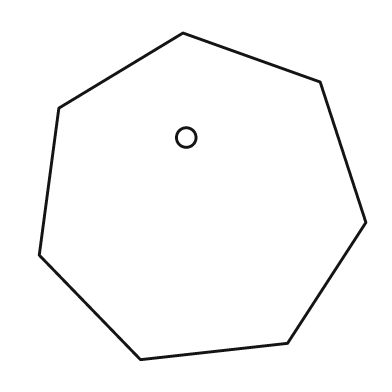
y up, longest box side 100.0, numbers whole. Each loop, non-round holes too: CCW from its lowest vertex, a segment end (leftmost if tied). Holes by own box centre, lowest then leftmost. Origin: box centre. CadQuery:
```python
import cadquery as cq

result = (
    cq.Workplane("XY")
    .moveTo(-19.0, -50.0)
    .lineTo(26.0, -45.0)
    .lineTo(50.0, -8.0)
    .lineTo(36.0, 35.0)
    .lineTo(-6.0, 50.0)
    .lineTo(-44.0, 27.0)
    .lineTo(-50.0, -18.0)
    .close()
    .moveTo(-5.0, 18.0)
    .circle(3.0)
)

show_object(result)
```